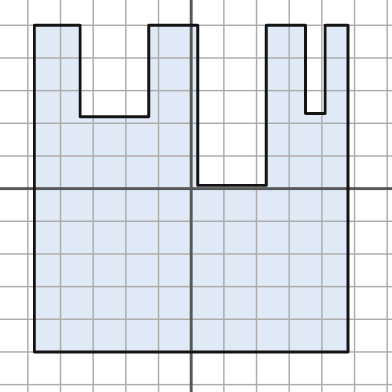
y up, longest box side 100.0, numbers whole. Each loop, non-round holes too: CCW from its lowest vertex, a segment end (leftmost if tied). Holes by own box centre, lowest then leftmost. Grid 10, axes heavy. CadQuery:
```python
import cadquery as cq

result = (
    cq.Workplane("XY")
    .moveTo(-48.0, -50.0)
    .lineTo(48.0, -50.0)
    .lineTo(48.0, 50.0)
    .lineTo(41.0, 50.0)
    .lineTo(41.0, 23.0)
    .lineTo(35.0, 23.0)
    .lineTo(35.0, 50.0)
    .lineTo(23.0, 50.0)
    .lineTo(23.0, 1.0)
    .lineTo(2.0, 1.0)
    .lineTo(2.0, 50.0)
    .lineTo(-13.0, 50.0)
    .lineTo(-13.0, 22.0)
    .lineTo(-34.0, 22.0)
    .lineTo(-34.0, 50.0)
    .lineTo(-48.0, 50.0)
    .close()
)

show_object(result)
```